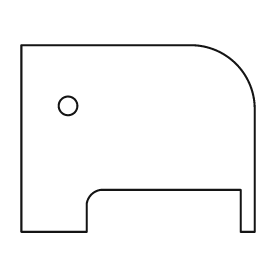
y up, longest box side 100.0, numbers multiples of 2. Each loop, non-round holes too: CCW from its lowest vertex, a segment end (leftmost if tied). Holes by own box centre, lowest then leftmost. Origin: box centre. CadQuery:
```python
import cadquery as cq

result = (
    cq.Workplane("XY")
    .moveTo(-50.0, -40.0)
    .lineTo(-22.0, -40.0)
    .lineTo(-22.0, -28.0)
    .threePointArc((-20.0, -24.0), (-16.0, -22.0))
    .lineTo(44.0, -22.0)
    .lineTo(44.0, -40.0)
    .lineTo(50.0, -40.0)
    .lineTo(50.0, 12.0)
    .threePointArc((42.0, 32.0), (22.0, 40.0))
    .lineTo(-50.0, 40.0)
    .close()
    .moveTo(-30.0, 14.0)
    .circle(4.0)
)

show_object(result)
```